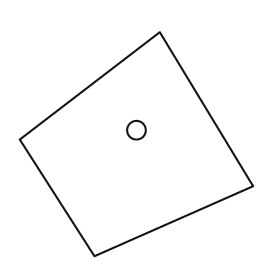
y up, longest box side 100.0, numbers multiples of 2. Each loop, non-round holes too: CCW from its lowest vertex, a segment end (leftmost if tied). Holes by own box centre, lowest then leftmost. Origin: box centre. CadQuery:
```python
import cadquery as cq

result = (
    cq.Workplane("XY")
    .moveTo(-18.0, -48.0)
    .lineTo(50.0, -18.0)
    .lineTo(10.0, 48.0)
    .lineTo(-50.0, 2.0)
    .close()
    .moveTo(0.0, 6.0)
    .circle(4.0)
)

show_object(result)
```